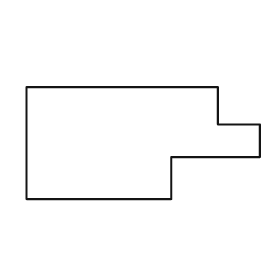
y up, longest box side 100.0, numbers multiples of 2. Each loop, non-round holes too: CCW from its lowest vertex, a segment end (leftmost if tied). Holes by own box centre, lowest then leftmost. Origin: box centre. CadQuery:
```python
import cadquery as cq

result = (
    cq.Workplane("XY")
    .moveTo(-50.0, -24.0)
    .lineTo(12.0, -24.0)
    .lineTo(12.0, -6.0)
    .lineTo(50.0, -6.0)
    .lineTo(50.0, 8.0)
    .lineTo(32.0, 8.0)
    .lineTo(32.0, 24.0)
    .lineTo(-50.0, 24.0)
    .close()
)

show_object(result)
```